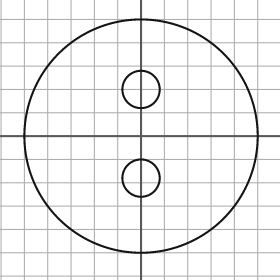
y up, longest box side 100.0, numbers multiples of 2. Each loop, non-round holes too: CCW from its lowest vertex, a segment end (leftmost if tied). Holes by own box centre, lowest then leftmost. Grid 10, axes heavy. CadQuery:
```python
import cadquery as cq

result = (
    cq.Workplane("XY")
    .moveTo(0.0, 0.0)
    .circle(50.0)
    .moveTo(0.0, -18.0)
    .circle(8.0)
    .moveTo(0.0, 20.0)
    .circle(8.0)
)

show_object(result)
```